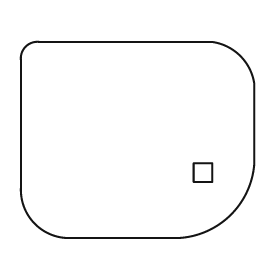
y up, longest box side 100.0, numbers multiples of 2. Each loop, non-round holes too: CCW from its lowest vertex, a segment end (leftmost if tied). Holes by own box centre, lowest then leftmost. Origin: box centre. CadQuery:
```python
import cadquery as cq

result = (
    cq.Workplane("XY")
    .moveTo(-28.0, -42.0)
    .lineTo(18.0, -42.0)
    .threePointArc((40.0, -32.0), (50.0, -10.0))
    .lineTo(50.0, 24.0)
    .threePointArc((44.0, 36.0), (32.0, 42.0))
    .lineTo(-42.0, 42.0)
    .threePointArc((-48.0, 40.0), (-50.0, 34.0))
    .lineTo(-50.0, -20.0)
    .threePointArc((-44.0, -36.0), (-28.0, -42.0))
    .close()
    .moveTo(24.0, -18.0)
    .lineTo(32.0, -18.0)
    .lineTo(32.0, -10.0)
    .lineTo(24.0, -10.0)
    .close()
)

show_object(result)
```